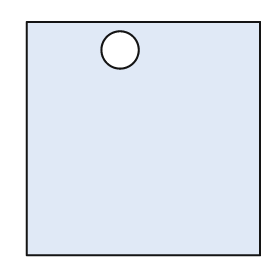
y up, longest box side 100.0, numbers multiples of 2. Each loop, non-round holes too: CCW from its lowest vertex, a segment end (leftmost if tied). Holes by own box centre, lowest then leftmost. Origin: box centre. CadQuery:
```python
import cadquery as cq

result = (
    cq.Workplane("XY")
    .moveTo(-50.0, -50.0)
    .lineTo(50.0, -50.0)
    .lineTo(50.0, 50.0)
    .lineTo(-50.0, 50.0)
    .close()
    .moveTo(-10.0, 38.0)
    .circle(8.0)
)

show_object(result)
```